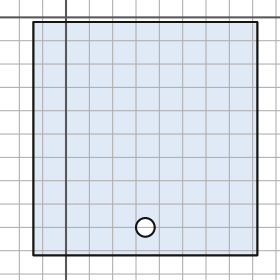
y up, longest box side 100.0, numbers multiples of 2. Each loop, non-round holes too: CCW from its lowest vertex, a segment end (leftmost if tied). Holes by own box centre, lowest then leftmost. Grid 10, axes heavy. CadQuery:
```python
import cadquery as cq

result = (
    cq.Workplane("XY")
    .moveTo(-14.0, -102.0)
    .lineTo(82.0, -102.0)
    .lineTo(82.0, -2.0)
    .lineTo(-14.0, -2.0)
    .close()
    .moveTo(34.0, -90.0)
    .circle(4.0)
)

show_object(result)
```